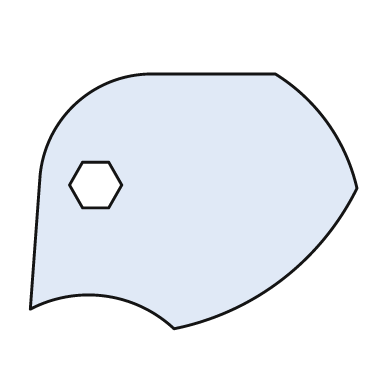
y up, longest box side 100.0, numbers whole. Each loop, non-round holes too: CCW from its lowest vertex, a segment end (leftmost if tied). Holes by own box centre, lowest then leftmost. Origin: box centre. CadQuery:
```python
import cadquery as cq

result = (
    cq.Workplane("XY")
    .moveTo(-6.0, -39.0)
    .threePointArc((27.0, -24.0), (50.0, 4.0))
    .threePointArc((41.0, 24.0), (25.0, 39.0))
    .lineTo(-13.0, 39.0)
    .threePointArc((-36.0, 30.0), (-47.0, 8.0))
    .lineTo(-50.0, -33.0)
    .threePointArc((-27.0, -29.0), (-6.0, -39.0))
    .close()
    .moveTo(-34.0, -2.0)
    .lineTo(-26.0, -2.0)
    .lineTo(-22.0, 5.0)
    .lineTo(-26.0, 12.0)
    .lineTo(-34.0, 12.0)
    .lineTo(-38.0, 5.0)
    .close()
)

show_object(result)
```